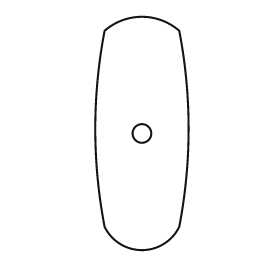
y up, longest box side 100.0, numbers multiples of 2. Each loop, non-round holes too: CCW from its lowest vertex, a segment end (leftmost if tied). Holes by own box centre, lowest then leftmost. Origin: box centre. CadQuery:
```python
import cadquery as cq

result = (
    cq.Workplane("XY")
    .moveTo(-16.0, -40.0)
    .threePointArc((0.0, -50.0), (16.0, -40.0))
    .threePointArc((20.0, 2.0), (16.0, 44.0))
    .threePointArc((0.0, 50.0), (-16.0, 44.0))
    .threePointArc((-20.0, 2.0), (-16.0, -40.0))
    .close()
    .moveTo(0.0, 0.0)
    .circle(4.0)
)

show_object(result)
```